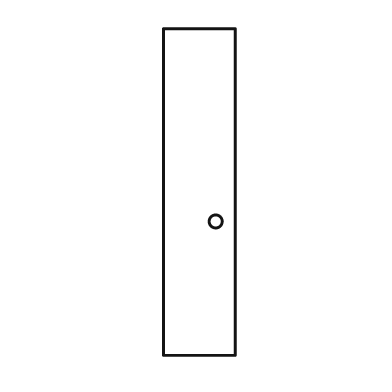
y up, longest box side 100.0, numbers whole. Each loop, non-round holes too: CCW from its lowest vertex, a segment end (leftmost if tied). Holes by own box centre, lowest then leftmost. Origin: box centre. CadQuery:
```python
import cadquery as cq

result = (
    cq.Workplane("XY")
    .moveTo(-11.0, -50.0)
    .lineTo(11.0, -50.0)
    .lineTo(11.0, 50.0)
    .lineTo(-11.0, 50.0)
    .close()
    .moveTo(5.0, -9.0)
    .circle(2.0)
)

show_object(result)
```